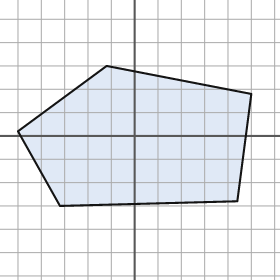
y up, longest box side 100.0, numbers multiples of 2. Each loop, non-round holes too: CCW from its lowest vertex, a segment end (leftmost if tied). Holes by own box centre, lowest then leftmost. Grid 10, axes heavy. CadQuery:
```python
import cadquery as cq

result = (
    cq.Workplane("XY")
    .moveTo(-32.0, -30.0)
    .lineTo(44.0, -28.0)
    .lineTo(50.0, 18.0)
    .lineTo(-12.0, 30.0)
    .lineTo(-50.0, 2.0)
    .close()
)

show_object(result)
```